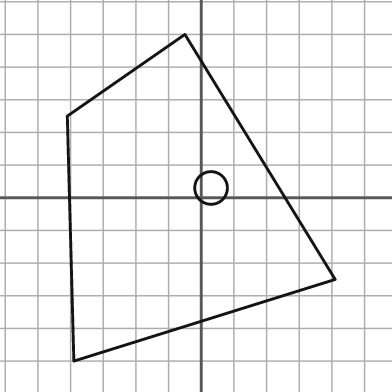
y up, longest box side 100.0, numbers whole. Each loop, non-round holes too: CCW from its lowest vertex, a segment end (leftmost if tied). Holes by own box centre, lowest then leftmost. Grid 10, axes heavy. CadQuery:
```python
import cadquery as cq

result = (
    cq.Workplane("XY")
    .moveTo(-39.0, -50.0)
    .lineTo(41.0, -25.0)
    .lineTo(-5.0, 50.0)
    .lineTo(-41.0, 25.0)
    .close()
    .moveTo(3.0, 3.0)
    .circle(5.0)
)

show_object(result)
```